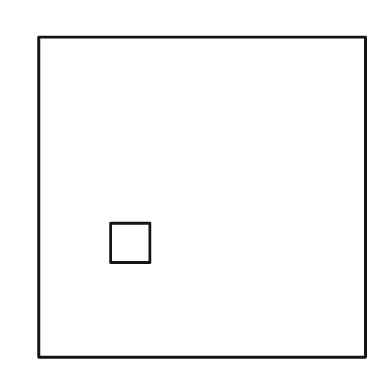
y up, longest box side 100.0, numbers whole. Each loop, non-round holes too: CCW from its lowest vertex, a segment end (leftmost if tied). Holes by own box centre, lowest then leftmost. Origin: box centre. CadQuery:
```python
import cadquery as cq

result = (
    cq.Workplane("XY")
    .moveTo(-50.0, -49.0)
    .lineTo(50.0, -49.0)
    .lineTo(50.0, 49.0)
    .lineTo(-50.0, 49.0)
    .close()
    .moveTo(-28.0, -20.0)
    .lineTo(-16.0, -20.0)
    .lineTo(-16.0, -8.0)
    .lineTo(-28.0, -8.0)
    .close()
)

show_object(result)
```